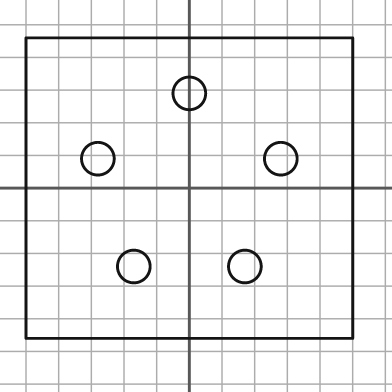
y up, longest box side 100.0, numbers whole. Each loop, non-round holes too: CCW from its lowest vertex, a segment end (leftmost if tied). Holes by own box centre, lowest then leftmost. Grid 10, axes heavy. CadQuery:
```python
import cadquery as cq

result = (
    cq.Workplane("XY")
    .moveTo(-50.0, -46.0)
    .lineTo(50.0, -46.0)
    .lineTo(50.0, 46.0)
    .lineTo(-50.0, 46.0)
    .close()
    .moveTo(-17.0, -24.0)
    .circle(5.0)
    .moveTo(17.0, -24.0)
    .circle(5.0)
    .moveTo(-28.0, 9.0)
    .circle(5.0)
    .moveTo(28.0, 9.0)
    .circle(5.0)
    .moveTo(0.0, 29.0)
    .circle(5.0)
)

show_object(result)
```